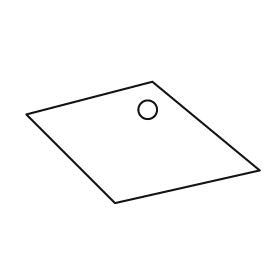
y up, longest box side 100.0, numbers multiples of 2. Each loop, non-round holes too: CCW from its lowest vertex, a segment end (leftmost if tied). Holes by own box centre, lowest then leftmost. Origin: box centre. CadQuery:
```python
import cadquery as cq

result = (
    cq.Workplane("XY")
    .moveTo(-12.0, -26.0)
    .lineTo(50.0, -12.0)
    .lineTo(4.0, 26.0)
    .lineTo(-50.0, 12.0)
    .close()
    .moveTo(2.0, 14.0)
    .circle(4.0)
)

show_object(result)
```